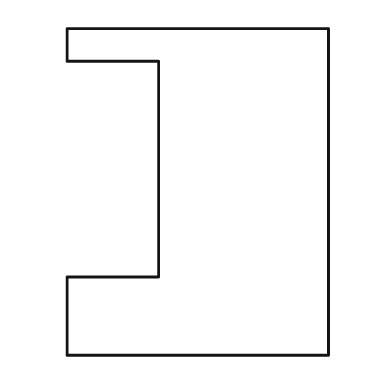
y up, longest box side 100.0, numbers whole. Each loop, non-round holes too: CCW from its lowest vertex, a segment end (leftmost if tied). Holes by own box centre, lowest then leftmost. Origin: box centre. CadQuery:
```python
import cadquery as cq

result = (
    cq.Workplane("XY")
    .moveTo(-40.0, -50.0)
    .lineTo(40.0, -50.0)
    .lineTo(40.0, 50.0)
    .lineTo(-40.0, 50.0)
    .lineTo(-40.0, 40.0)
    .lineTo(-12.0, 40.0)
    .lineTo(-12.0, -26.0)
    .lineTo(-40.0, -26.0)
    .close()
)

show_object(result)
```